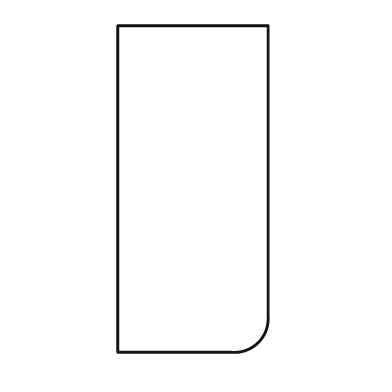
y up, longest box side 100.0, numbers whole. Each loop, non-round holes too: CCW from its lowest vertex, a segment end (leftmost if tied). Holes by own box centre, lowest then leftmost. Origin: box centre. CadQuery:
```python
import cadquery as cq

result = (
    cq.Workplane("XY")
    .moveTo(-23.0, -50.0)
    .lineTo(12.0, -50.0)
    .threePointArc((20.0, -47.0), (23.0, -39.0))
    .lineTo(23.0, 50.0)
    .lineTo(-23.0, 50.0)
    .close()
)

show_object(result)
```